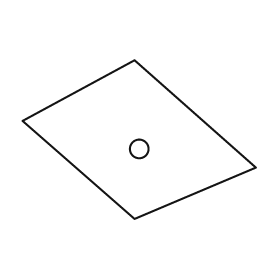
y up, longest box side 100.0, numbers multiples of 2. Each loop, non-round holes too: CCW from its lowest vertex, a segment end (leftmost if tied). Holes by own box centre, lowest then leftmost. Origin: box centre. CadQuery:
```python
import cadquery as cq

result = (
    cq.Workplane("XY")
    .moveTo(-2.0, -34.0)
    .lineTo(50.0, -12.0)
    .lineTo(-2.0, 34.0)
    .lineTo(-50.0, 8.0)
    .close()
    .moveTo(0.0, -4.0)
    .circle(4.0)
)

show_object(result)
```